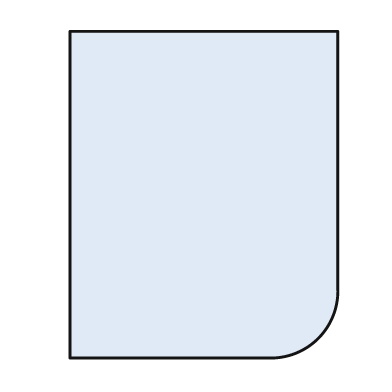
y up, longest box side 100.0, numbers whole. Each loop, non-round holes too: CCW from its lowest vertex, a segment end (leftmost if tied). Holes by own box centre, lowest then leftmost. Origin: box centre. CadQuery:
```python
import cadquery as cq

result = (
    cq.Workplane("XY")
    .moveTo(-41.0, -50.0)
    .lineTo(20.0, -50.0)
    .threePointArc((35.0, -44.0), (41.0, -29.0))
    .lineTo(41.0, 50.0)
    .lineTo(-41.0, 50.0)
    .close()
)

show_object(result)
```